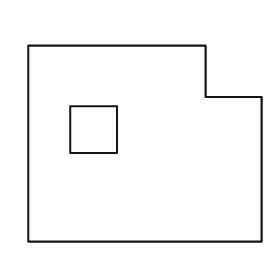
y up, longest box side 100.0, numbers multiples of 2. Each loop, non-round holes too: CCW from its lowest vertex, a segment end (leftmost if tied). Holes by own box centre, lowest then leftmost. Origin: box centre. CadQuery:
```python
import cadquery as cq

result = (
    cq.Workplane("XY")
    .moveTo(-50.0, -42.0)
    .lineTo(50.0, -42.0)
    .lineTo(50.0, 20.0)
    .lineTo(26.0, 20.0)
    .lineTo(26.0, 42.0)
    .lineTo(-50.0, 42.0)
    .close()
    .moveTo(-32.0, -4.0)
    .lineTo(-12.0, -4.0)
    .lineTo(-12.0, 16.0)
    .lineTo(-32.0, 16.0)
    .close()
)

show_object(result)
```